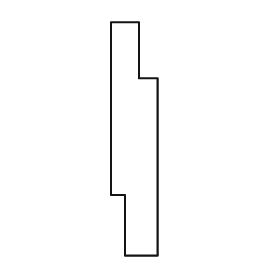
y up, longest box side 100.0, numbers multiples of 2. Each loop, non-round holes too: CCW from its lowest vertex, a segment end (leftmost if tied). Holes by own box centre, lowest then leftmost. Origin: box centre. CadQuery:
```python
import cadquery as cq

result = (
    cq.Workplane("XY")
    .moveTo(-4.0, -50.0)
    .lineTo(10.0, -50.0)
    .lineTo(10.0, 26.0)
    .lineTo(2.0, 26.0)
    .lineTo(2.0, 50.0)
    .lineTo(-10.0, 50.0)
    .lineTo(-10.0, -24.0)
    .lineTo(-4.0, -24.0)
    .close()
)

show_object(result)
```